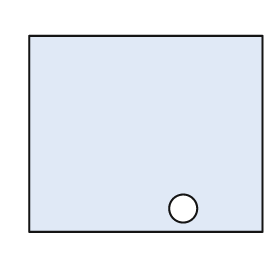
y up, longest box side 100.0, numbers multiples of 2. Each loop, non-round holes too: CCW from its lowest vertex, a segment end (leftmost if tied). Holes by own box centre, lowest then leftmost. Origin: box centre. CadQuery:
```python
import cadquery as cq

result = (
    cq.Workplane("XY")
    .moveTo(-50.0, -42.0)
    .lineTo(50.0, -42.0)
    .lineTo(50.0, 42.0)
    .lineTo(-50.0, 42.0)
    .close()
    .moveTo(16.0, -32.0)
    .circle(6.0)
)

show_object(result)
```